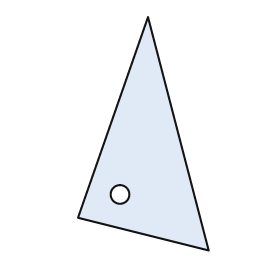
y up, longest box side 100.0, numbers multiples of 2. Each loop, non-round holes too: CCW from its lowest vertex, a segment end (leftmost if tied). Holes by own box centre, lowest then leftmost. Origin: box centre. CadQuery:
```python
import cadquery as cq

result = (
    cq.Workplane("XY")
    .moveTo(28.0, -50.0)
    .lineTo(2.0, 50.0)
    .lineTo(-28.0, -36.0)
    .close()
    .moveTo(-10.0, -26.0)
    .circle(4.0)
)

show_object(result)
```